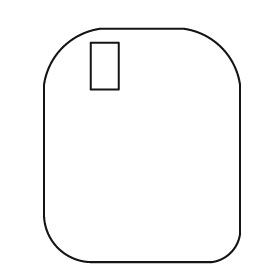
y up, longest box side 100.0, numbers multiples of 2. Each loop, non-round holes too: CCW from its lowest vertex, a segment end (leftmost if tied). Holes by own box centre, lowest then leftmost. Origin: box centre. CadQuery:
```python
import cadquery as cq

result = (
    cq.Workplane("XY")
    .moveTo(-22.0, -50.0)
    .lineTo(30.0, -50.0)
    .threePointArc((38.0, -46.0), (42.0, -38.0))
    .lineTo(42.0, 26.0)
    .threePointArc((34.0, 42.0), (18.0, 50.0))
    .lineTo(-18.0, 50.0)
    .threePointArc((-34.0, 42.0), (-42.0, 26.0))
    .lineTo(-42.0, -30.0)
    .threePointArc((-36.0, -44.0), (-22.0, -50.0))
    .close()
    .moveTo(-22.0, 24.0)
    .lineTo(-10.0, 24.0)
    .lineTo(-10.0, 44.0)
    .lineTo(-22.0, 44.0)
    .close()
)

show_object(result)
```